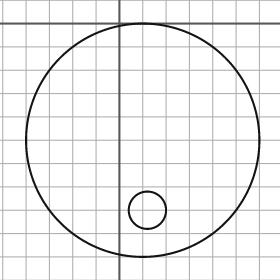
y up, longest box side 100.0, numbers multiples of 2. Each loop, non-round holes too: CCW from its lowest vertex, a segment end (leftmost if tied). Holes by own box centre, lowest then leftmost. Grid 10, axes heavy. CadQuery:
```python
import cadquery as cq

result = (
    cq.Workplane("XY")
    .moveTo(10.0, -50.0)
    .circle(50.0)
    .moveTo(12.0, -80.0)
    .circle(8.0)
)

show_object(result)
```